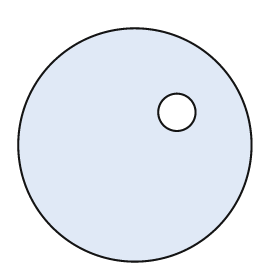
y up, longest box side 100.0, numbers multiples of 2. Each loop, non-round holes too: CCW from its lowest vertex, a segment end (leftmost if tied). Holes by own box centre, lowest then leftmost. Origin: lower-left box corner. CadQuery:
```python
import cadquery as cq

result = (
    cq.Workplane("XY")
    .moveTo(50.0, 50.0)
    .circle(50.0)
    .moveTo(68.0, 64.0)
    .circle(8.0)
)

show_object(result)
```